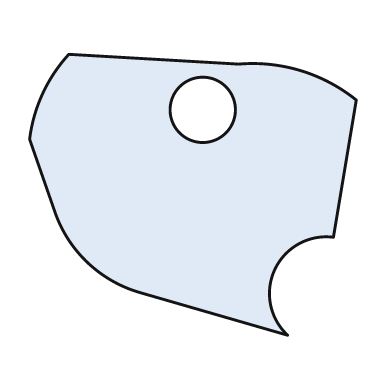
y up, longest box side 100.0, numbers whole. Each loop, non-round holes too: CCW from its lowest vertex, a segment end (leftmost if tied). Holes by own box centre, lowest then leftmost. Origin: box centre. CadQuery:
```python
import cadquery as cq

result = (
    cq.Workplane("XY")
    .moveTo(29.0, -43.0)
    .threePointArc((25.0, -23.0), (43.0, -13.0))
    .lineTo(50.0, 29.0)
    .threePointArc((33.0, 38.0), (14.0, 40.0))
    .lineTo(-38.0, 43.0)
    .threePointArc((-46.0, 31.0), (-50.0, 17.0))
    .lineTo(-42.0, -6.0)
    .threePointArc((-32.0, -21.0), (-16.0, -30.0))
    .close()
    .moveTo(3.0, 26.0)
    .circle(10.0)
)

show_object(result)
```